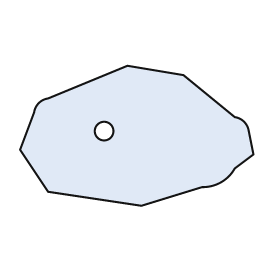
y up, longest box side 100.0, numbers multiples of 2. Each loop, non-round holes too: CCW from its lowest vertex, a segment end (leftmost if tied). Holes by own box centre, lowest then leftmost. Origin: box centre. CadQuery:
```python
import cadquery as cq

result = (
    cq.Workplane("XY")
    .moveTo(2.0, -30.0)
    .lineTo(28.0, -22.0)
    .threePointArc((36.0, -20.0), (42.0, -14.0))
    .lineTo(50.0, -8.0)
    .lineTo(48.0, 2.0)
    .threePointArc((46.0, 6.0), (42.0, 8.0))
    .lineTo(20.0, 26.0)
    .lineTo(-4.0, 30.0)
    .lineTo(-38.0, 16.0)
    .threePointArc((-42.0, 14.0), (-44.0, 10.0))
    .lineTo(-50.0, -6.0)
    .lineTo(-38.0, -24.0)
    .close()
    .moveTo(-14.0, 2.0)
    .circle(4.0)
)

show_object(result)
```